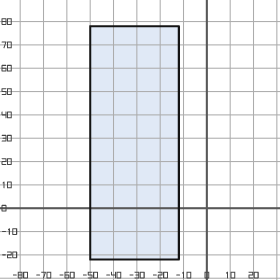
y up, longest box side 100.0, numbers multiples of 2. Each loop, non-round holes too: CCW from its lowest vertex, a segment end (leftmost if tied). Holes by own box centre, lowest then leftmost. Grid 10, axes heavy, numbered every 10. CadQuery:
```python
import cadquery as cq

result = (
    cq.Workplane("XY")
    .moveTo(-50.0, -22.0)
    .lineTo(-12.0, -22.0)
    .lineTo(-12.0, 78.0)
    .lineTo(-50.0, 78.0)
    .close()
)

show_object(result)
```